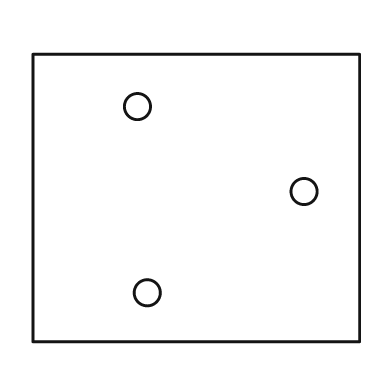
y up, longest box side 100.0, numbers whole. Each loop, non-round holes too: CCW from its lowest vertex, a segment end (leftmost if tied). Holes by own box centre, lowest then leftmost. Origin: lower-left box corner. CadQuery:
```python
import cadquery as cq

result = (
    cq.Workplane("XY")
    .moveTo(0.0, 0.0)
    .lineTo(100.0, 0.0)
    .lineTo(100.0, 88.0)
    .lineTo(0.0, 88.0)
    .close()
    .moveTo(35.0, 15.0)
    .circle(4.0)
    .moveTo(83.0, 46.0)
    .circle(4.0)
    .moveTo(32.0, 72.0)
    .circle(4.0)
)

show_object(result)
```